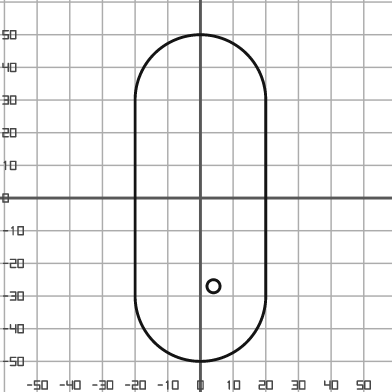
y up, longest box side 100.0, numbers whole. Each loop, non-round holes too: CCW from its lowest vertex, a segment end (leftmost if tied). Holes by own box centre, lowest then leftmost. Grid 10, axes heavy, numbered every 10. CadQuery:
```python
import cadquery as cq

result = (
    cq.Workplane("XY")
    .moveTo(-20.0, -30.0)
    .threePointArc((0.0, -50.0), (20.0, -30.0))
    .lineTo(20.0, 30.0)
    .threePointArc((0.0, 50.0), (-20.0, 30.0))
    .close()
    .moveTo(4.0, -27.0)
    .circle(2.0)
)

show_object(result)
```